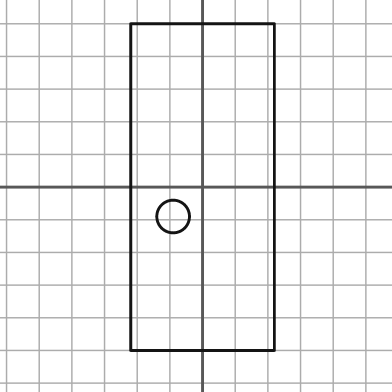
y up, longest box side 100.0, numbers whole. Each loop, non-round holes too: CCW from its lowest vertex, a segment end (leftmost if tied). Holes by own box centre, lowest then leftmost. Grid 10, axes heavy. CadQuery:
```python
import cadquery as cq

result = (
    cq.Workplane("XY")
    .moveTo(-22.0, -50.0)
    .lineTo(22.0, -50.0)
    .lineTo(22.0, 50.0)
    .lineTo(-22.0, 50.0)
    .close()
    .moveTo(-9.0, -9.0)
    .circle(5.0)
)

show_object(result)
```